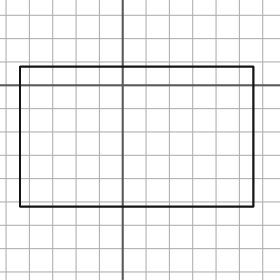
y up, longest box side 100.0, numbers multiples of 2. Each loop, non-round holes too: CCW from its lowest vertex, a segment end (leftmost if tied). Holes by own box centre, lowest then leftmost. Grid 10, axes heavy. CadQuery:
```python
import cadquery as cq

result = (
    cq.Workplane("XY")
    .moveTo(-44.0, -52.0)
    .lineTo(56.0, -52.0)
    .lineTo(56.0, 8.0)
    .lineTo(-44.0, 8.0)
    .close()
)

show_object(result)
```